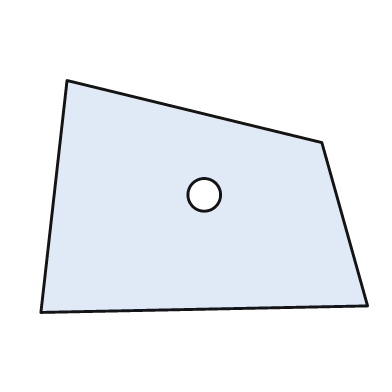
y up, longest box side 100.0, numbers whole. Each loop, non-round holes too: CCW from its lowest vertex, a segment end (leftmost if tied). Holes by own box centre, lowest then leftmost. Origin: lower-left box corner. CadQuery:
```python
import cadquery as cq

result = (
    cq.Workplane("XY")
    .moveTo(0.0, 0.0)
    .lineTo(100.0, 2.0)
    .lineTo(86.0, 52.0)
    .lineTo(8.0, 71.0)
    .close()
    .moveTo(50.0, 36.0)
    .circle(5.0)
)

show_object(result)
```